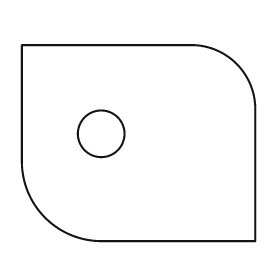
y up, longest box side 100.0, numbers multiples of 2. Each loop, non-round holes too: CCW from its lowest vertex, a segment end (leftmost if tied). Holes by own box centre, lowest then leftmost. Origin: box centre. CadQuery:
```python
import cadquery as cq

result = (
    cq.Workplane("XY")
    .moveTo(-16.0, -42.0)
    .lineTo(50.0, -42.0)
    .lineTo(50.0, 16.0)
    .threePointArc((42.0, 34.0), (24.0, 42.0))
    .lineTo(-50.0, 42.0)
    .lineTo(-50.0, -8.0)
    .threePointArc((-40.0, -32.0), (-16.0, -42.0))
    .close()
    .moveTo(-16.0, 4.0)
    .circle(10.0)
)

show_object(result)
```